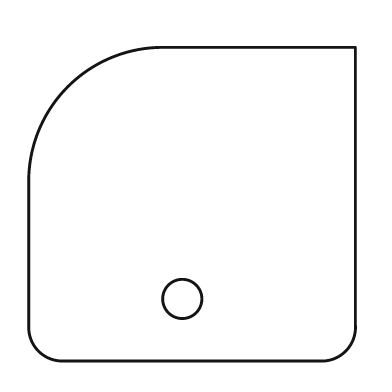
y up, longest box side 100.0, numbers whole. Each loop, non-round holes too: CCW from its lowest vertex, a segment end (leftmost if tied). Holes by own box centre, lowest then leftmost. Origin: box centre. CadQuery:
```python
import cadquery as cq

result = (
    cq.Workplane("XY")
    .moveTo(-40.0, -48.0)
    .lineTo(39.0, -48.0)
    .threePointArc((47.0, -45.0), (50.0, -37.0))
    .lineTo(50.0, 48.0)
    .lineTo(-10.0, 48.0)
    .threePointArc((-38.0, 36.0), (-50.0, 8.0))
    .lineTo(-50.0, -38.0)
    .threePointArc((-47.0, -45.0), (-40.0, -48.0))
    .close()
    .moveTo(-3.0, -29.0)
    .circle(6.0)
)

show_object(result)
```